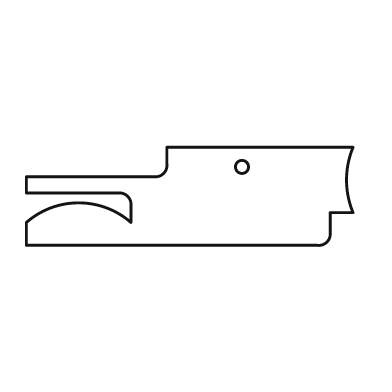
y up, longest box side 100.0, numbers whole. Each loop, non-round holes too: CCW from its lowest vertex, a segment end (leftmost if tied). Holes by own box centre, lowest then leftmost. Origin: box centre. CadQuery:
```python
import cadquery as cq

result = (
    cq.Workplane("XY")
    .moveTo(-50.0, -15.0)
    .lineTo(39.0, -15.0)
    .threePointArc((42.0, -14.0), (43.0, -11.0))
    .lineTo(43.0, -5.0)
    .lineTo(50.0, -5.0)
    .threePointArc((48.0, 5.0), (50.0, 15.0))
    .lineTo(-7.0, 15.0)
    .lineTo(-7.0, 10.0)
    .threePointArc((-8.0, 7.0), (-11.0, 6.0))
    .lineTo(-50.0, 6.0)
    .lineTo(-50.0, 1.0)
    .lineTo(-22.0, 1.0)
    .threePointArc((-19.0, 0.0), (-18.0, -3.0))
    .lineTo(-18.0, -8.0)
    .threePointArc((-34.0, -2.0), (-50.0, -8.0))
    .close()
    .moveTo(16.0, 9.0)
    .circle(2.0)
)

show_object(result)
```